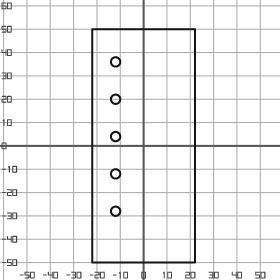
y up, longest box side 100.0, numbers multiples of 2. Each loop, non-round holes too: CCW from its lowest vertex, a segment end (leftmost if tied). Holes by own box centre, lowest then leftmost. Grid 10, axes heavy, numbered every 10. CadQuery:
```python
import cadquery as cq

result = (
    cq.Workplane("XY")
    .moveTo(-22.0, -50.0)
    .lineTo(22.0, -50.0)
    .lineTo(22.0, 50.0)
    .lineTo(-22.0, 50.0)
    .close()
    .moveTo(-12.0, -28.0)
    .circle(2.0)
    .moveTo(-12.0, -12.0)
    .circle(2.0)
    .moveTo(-12.0, 4.0)
    .circle(2.0)
    .moveTo(-12.0, 20.0)
    .circle(2.0)
    .moveTo(-12.0, 36.0)
    .circle(2.0)
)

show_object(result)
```